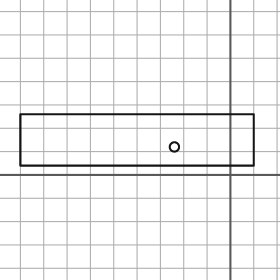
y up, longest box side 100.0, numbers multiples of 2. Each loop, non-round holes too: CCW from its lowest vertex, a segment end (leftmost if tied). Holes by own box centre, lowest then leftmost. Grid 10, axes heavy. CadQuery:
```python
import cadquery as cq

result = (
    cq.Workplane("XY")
    .moveTo(-90.0, 4.0)
    .lineTo(10.0, 4.0)
    .lineTo(10.0, 26.0)
    .lineTo(-90.0, 26.0)
    .close()
    .moveTo(-24.0, 12.0)
    .circle(2.0)
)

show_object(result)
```